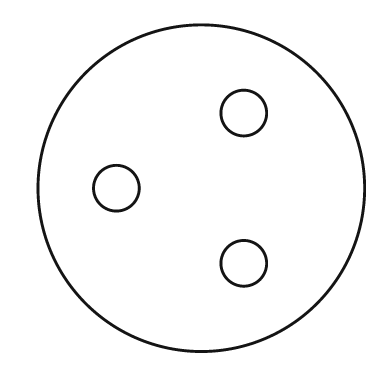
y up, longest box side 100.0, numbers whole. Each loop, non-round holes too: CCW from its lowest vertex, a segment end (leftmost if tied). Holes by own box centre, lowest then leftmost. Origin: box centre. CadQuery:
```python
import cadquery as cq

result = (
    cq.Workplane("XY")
    .moveTo(0.0, 0.0)
    .circle(50.0)
    .moveTo(13.0, -23.0)
    .circle(7.0)
    .moveTo(-26.0, 0.0)
    .circle(7.0)
    .moveTo(13.0, 23.0)
    .circle(7.0)
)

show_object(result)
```